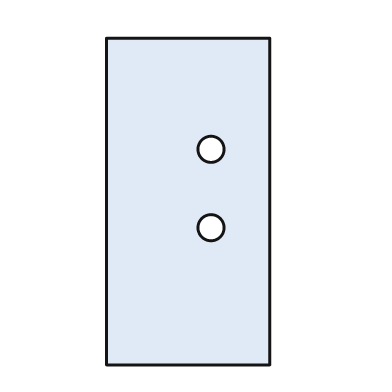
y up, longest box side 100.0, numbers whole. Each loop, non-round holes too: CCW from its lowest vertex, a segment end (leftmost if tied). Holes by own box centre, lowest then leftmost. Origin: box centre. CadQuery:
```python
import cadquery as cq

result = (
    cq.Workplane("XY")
    .moveTo(-25.0, -50.0)
    .lineTo(25.0, -50.0)
    .lineTo(25.0, 50.0)
    .lineTo(-25.0, 50.0)
    .close()
    .moveTo(7.0, -8.0)
    .circle(4.0)
    .moveTo(7.0, 16.0)
    .circle(4.0)
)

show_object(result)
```